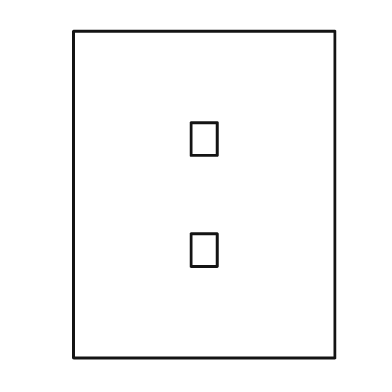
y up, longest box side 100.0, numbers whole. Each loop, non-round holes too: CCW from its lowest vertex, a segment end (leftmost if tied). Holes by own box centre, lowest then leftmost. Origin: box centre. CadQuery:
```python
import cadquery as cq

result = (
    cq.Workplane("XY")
    .moveTo(-40.0, -50.0)
    .lineTo(40.0, -50.0)
    .lineTo(40.0, 50.0)
    .lineTo(-40.0, 50.0)
    .close()
    .moveTo(-4.0, -22.0)
    .lineTo(4.0, -22.0)
    .lineTo(4.0, -12.0)
    .lineTo(-4.0, -12.0)
    .close()
    .moveTo(-4.0, 12.0)
    .lineTo(4.0, 12.0)
    .lineTo(4.0, 22.0)
    .lineTo(-4.0, 22.0)
    .close()
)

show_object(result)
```